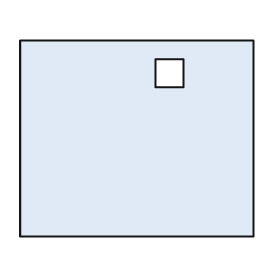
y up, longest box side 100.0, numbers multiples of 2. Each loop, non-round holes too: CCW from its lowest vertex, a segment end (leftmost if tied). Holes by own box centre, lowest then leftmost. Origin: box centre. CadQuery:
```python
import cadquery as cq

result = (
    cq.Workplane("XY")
    .moveTo(-50.0, -42.0)
    .lineTo(50.0, -42.0)
    .lineTo(50.0, 42.0)
    .lineTo(-50.0, 42.0)
    .close()
    .moveTo(8.0, 22.0)
    .lineTo(20.0, 22.0)
    .lineTo(20.0, 34.0)
    .lineTo(8.0, 34.0)
    .close()
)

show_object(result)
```